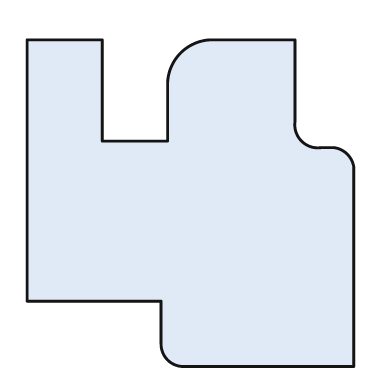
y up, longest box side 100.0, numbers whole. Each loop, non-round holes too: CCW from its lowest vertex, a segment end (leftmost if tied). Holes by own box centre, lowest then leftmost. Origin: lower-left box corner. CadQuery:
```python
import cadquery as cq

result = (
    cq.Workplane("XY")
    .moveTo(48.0, 0.0)
    .lineTo(100.0, 0.0)
    .lineTo(100.0, 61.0)
    .threePointArc((98.0, 65.0), (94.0, 67.0))
    .lineTo(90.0, 67.0)
    .threePointArc((84.0, 69.0), (82.0, 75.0))
    .lineTo(82.0, 100.0)
    .lineTo(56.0, 100.0)
    .threePointArc((47.0, 96.0), (43.0, 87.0))
    .lineTo(43.0, 69.0)
    .lineTo(23.0, 69.0)
    .lineTo(23.0, 100.0)
    .lineTo(0.0, 100.0)
    .lineTo(0.0, 20.0)
    .lineTo(41.0, 20.0)
    .lineTo(41.0, 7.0)
    .threePointArc((43.0, 2.0), (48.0, 0.0))
    .close()
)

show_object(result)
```